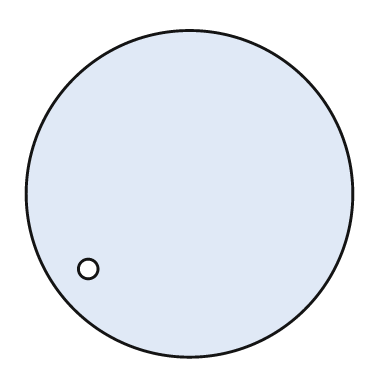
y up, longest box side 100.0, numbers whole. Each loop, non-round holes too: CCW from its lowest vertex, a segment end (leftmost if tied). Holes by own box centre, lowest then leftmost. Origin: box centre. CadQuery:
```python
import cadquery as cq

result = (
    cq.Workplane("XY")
    .moveTo(0.0, 0.0)
    .circle(50.0)
    .moveTo(-31.0, -23.0)
    .circle(3.0)
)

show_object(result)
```